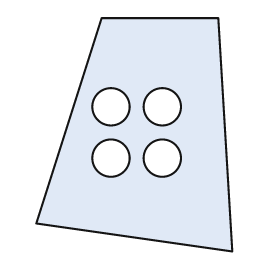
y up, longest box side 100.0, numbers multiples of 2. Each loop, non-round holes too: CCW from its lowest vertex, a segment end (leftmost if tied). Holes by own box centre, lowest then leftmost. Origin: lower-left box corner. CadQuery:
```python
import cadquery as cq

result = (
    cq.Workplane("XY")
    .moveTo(84.0, 0.0)
    .lineTo(78.0, 100.0)
    .lineTo(28.0, 100.0)
    .lineTo(0.0, 12.0)
    .close()
    .moveTo(32.0, 40.0)
    .circle(8.0)
    .moveTo(54.0, 40.0)
    .circle(8.0)
    .moveTo(32.0, 62.0)
    .circle(8.0)
    .moveTo(54.0, 62.0)
    .circle(8.0)
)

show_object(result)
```